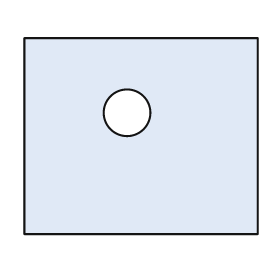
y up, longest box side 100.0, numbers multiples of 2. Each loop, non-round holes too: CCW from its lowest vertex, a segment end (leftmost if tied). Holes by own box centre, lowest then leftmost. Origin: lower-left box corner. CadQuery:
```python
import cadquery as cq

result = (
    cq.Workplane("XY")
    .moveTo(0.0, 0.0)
    .lineTo(100.0, 0.0)
    .lineTo(100.0, 84.0)
    .lineTo(0.0, 84.0)
    .close()
    .moveTo(44.0, 52.0)
    .circle(10.0)
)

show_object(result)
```